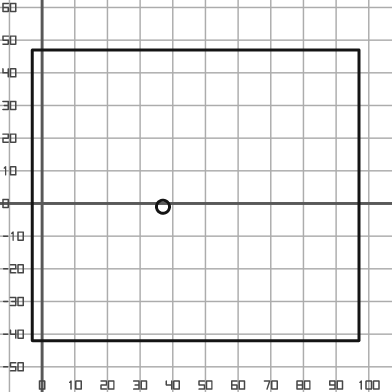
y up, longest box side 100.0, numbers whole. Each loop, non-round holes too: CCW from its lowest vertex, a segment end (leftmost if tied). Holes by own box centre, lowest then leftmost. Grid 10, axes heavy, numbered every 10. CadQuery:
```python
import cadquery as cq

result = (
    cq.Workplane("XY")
    .moveTo(-3.0, -42.0)
    .lineTo(97.0, -42.0)
    .lineTo(97.0, 47.0)
    .lineTo(-3.0, 47.0)
    .close()
    .moveTo(37.0, -1.0)
    .circle(2.0)
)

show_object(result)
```